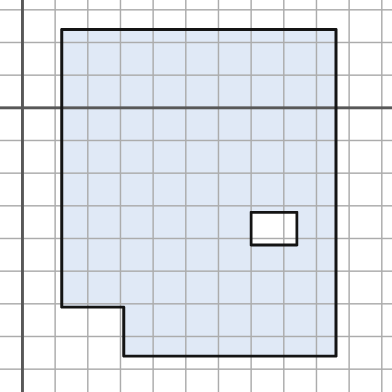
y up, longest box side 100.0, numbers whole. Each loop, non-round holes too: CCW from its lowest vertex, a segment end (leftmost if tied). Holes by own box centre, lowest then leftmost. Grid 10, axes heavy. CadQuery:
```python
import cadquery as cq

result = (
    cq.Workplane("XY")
    .moveTo(31.0, -76.0)
    .lineTo(96.0, -76.0)
    .lineTo(96.0, 24.0)
    .lineTo(12.0, 24.0)
    .lineTo(12.0, -61.0)
    .lineTo(31.0, -61.0)
    .close()
    .moveTo(70.0, -42.0)
    .lineTo(84.0, -42.0)
    .lineTo(84.0, -32.0)
    .lineTo(70.0, -32.0)
    .close()
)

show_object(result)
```